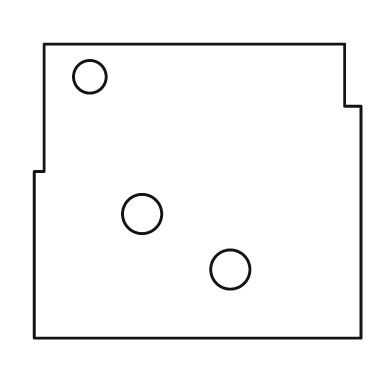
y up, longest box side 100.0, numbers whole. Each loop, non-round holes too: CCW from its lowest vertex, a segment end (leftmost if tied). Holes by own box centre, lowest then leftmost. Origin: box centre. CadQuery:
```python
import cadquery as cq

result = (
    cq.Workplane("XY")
    .moveTo(-50.0, -45.0)
    .lineTo(50.0, -45.0)
    .lineTo(50.0, 26.0)
    .lineTo(45.0, 26.0)
    .lineTo(45.0, 45.0)
    .lineTo(-47.0, 45.0)
    .lineTo(-47.0, 6.0)
    .lineTo(-50.0, 6.0)
    .close()
    .moveTo(10.0, -24.0)
    .circle(6.0)
    .moveTo(-17.0, -7.0)
    .circle(6.0)
    .moveTo(-33.0, 35.0)
    .circle(5.0)
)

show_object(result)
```